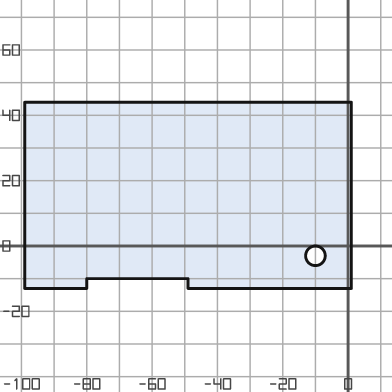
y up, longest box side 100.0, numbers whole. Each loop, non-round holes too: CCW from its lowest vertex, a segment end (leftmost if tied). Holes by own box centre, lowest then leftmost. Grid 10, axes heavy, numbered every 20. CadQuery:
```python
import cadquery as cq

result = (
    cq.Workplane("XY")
    .moveTo(-99.0, -13.0)
    .lineTo(-80.0, -13.0)
    .lineTo(-80.0, -10.0)
    .lineTo(-49.0, -10.0)
    .lineTo(-49.0, -13.0)
    .lineTo(1.0, -13.0)
    .lineTo(1.0, 44.0)
    .lineTo(-99.0, 44.0)
    .close()
    .moveTo(-10.0, -3.0)
    .circle(3.0)
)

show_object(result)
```